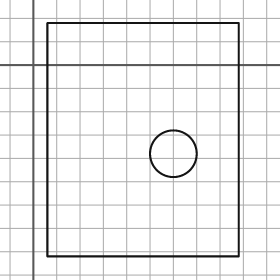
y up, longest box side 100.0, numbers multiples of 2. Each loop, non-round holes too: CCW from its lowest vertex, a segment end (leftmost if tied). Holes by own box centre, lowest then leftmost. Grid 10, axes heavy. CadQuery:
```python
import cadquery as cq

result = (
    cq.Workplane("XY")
    .moveTo(6.0, -82.0)
    .lineTo(88.0, -82.0)
    .lineTo(88.0, 18.0)
    .lineTo(6.0, 18.0)
    .close()
    .moveTo(60.0, -38.0)
    .circle(10.0)
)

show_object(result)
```